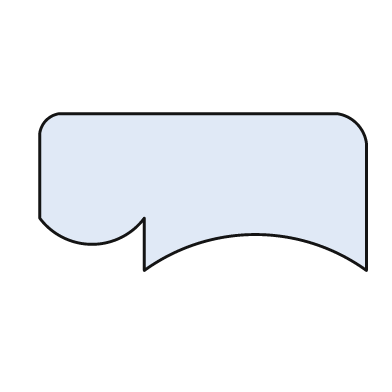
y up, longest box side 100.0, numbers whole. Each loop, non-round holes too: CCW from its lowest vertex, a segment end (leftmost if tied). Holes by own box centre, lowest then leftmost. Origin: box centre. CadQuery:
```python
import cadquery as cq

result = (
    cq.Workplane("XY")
    .moveTo(-18.0, -24.0)
    .threePointArc((16.0, -13.0), (50.0, -24.0))
    .lineTo(50.0, 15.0)
    .threePointArc((47.0, 21.0), (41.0, 24.0))
    .lineTo(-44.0, 24.0)
    .threePointArc((-48.0, 22.0), (-50.0, 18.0))
    .lineTo(-50.0, -8.0)
    .threePointArc((-34.0, -16.0), (-18.0, -8.0))
    .close()
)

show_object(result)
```